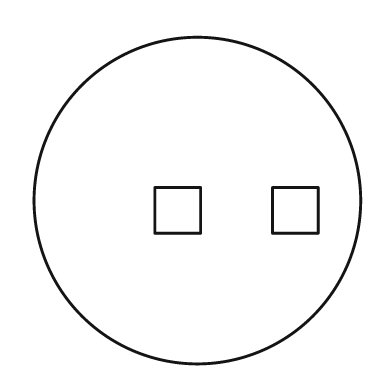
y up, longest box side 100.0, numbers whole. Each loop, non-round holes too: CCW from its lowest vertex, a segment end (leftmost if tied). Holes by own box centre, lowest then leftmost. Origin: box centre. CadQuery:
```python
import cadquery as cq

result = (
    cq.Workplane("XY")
    .moveTo(0.0, 0.0)
    .circle(50.0)
    .moveTo(-13.0, -10.0)
    .lineTo(1.0, -10.0)
    .lineTo(1.0, 4.0)
    .lineTo(-13.0, 4.0)
    .close()
    .moveTo(23.0, -10.0)
    .lineTo(37.0, -10.0)
    .lineTo(37.0, 4.0)
    .lineTo(23.0, 4.0)
    .close()
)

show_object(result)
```